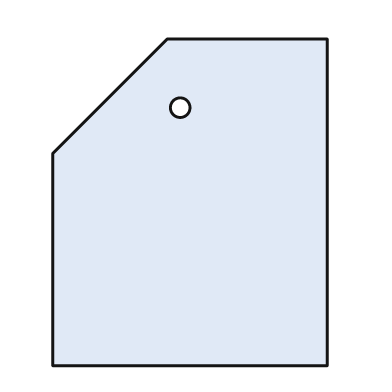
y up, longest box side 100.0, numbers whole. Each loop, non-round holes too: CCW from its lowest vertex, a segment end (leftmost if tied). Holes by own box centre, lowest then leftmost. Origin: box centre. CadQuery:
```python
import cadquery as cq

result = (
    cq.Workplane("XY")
    .moveTo(-42.0, -50.0)
    .lineTo(42.0, -50.0)
    .lineTo(42.0, 50.0)
    .lineTo(-7.0, 50.0)
    .lineTo(-42.0, 15.0)
    .close()
    .moveTo(-3.0, 29.0)
    .circle(3.0)
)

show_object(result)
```